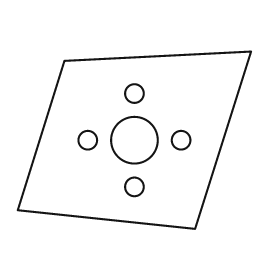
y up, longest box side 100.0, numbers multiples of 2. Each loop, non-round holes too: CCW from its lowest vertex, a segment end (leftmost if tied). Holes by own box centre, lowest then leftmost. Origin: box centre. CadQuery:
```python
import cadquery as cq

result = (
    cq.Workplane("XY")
    .moveTo(26.0, -38.0)
    .lineTo(50.0, 38.0)
    .lineTo(-30.0, 34.0)
    .lineTo(-50.0, -30.0)
    .close()
    .moveTo(0.0, -20.0)
    .circle(4.0)
    .moveTo(-20.0, 0.0)
    .circle(4.0)
    .moveTo(0.0, 0.0)
    .circle(10.0)
    .moveTo(20.0, 0.0)
    .circle(4.0)
    .moveTo(0.0, 20.0)
    .circle(4.0)
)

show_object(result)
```